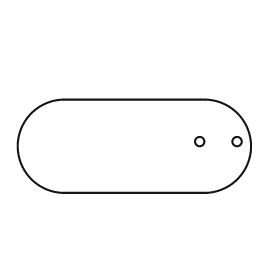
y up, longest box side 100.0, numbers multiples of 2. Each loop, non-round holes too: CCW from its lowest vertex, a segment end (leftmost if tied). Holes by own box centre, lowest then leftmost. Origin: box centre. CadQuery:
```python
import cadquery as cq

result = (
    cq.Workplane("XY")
    .moveTo(-30.0, -20.0)
    .lineTo(30.0, -20.0)
    .threePointArc((50.0, 0.0), (30.0, 20.0))
    .lineTo(-30.0, 20.0)
    .threePointArc((-50.0, 0.0), (-30.0, -20.0))
    .close()
    .moveTo(28.0, 2.0)
    .circle(2.0)
    .moveTo(44.0, 2.0)
    .circle(2.0)
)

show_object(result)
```